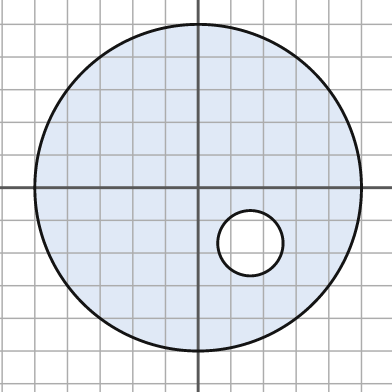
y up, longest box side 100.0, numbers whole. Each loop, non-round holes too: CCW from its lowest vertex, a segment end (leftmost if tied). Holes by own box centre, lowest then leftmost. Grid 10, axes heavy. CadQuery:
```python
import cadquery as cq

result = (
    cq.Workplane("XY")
    .moveTo(0.0, 0.0)
    .circle(50.0)
    .moveTo(16.0, -17.0)
    .circle(10.0)
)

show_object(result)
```